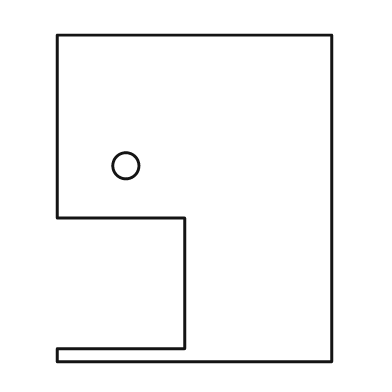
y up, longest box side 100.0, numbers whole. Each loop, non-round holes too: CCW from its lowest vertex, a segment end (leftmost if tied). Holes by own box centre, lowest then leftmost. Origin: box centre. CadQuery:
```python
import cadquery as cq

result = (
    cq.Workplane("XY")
    .moveTo(-42.0, -50.0)
    .lineTo(42.0, -50.0)
    .lineTo(42.0, 50.0)
    .lineTo(-42.0, 50.0)
    .lineTo(-42.0, -6.0)
    .lineTo(-3.0, -6.0)
    .lineTo(-3.0, -46.0)
    .lineTo(-42.0, -46.0)
    .close()
    .moveTo(-21.0, 10.0)
    .circle(4.0)
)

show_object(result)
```